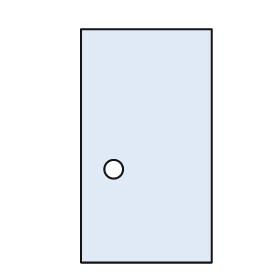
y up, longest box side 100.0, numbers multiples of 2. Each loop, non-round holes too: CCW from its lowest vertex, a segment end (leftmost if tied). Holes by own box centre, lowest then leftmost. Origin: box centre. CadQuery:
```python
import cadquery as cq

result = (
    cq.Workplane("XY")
    .moveTo(-28.0, -50.0)
    .lineTo(28.0, -50.0)
    .lineTo(28.0, 50.0)
    .lineTo(-28.0, 50.0)
    .close()
    .moveTo(-14.0, -10.0)
    .circle(4.0)
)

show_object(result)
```